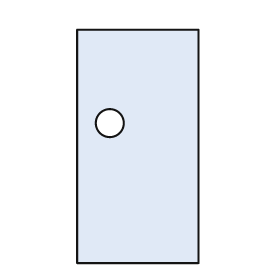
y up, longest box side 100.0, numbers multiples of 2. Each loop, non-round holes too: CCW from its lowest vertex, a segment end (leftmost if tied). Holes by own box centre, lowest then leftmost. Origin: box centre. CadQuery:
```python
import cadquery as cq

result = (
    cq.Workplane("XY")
    .moveTo(-26.0, -50.0)
    .lineTo(26.0, -50.0)
    .lineTo(26.0, 50.0)
    .lineTo(-26.0, 50.0)
    .close()
    .moveTo(-12.0, 10.0)
    .circle(6.0)
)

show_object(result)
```